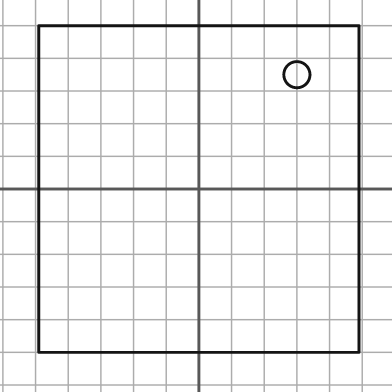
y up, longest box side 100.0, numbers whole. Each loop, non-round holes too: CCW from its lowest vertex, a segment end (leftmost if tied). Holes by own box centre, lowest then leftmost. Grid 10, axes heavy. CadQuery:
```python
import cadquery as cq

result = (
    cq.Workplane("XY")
    .moveTo(-49.0, -50.0)
    .lineTo(49.0, -50.0)
    .lineTo(49.0, 50.0)
    .lineTo(-49.0, 50.0)
    .close()
    .moveTo(30.0, 35.0)
    .circle(4.0)
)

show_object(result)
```